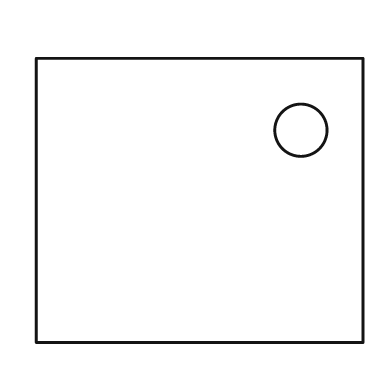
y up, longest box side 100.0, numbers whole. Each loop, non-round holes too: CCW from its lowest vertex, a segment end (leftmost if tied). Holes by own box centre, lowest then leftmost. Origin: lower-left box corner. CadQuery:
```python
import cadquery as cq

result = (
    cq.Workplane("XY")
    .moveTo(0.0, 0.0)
    .lineTo(100.0, 0.0)
    .lineTo(100.0, 87.0)
    .lineTo(0.0, 87.0)
    .close()
    .moveTo(81.0, 65.0)
    .circle(8.0)
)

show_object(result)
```